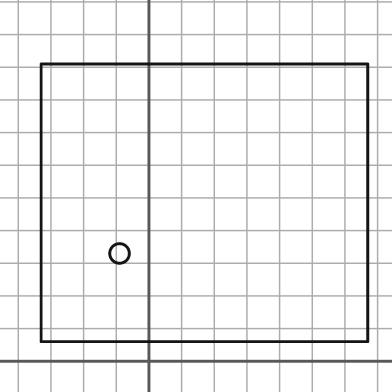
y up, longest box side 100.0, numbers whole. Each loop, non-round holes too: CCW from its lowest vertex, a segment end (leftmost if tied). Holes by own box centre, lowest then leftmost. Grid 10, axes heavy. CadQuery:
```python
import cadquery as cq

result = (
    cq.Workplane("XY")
    .moveTo(-33.0, 6.0)
    .lineTo(67.0, 6.0)
    .lineTo(67.0, 91.0)
    .lineTo(-33.0, 91.0)
    .close()
    .moveTo(-9.0, 33.0)
    .circle(3.0)
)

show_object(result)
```